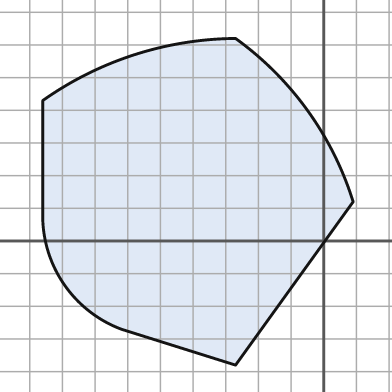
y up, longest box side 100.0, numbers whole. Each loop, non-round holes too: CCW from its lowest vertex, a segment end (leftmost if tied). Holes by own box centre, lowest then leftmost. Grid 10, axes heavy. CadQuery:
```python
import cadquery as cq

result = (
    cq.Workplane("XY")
    .moveTo(-27.0, -38.0)
    .lineTo(9.0, 12.0)
    .threePointArc((-5.0, 40.0), (-27.0, 62.0))
    .threePointArc((-58.0, 57.0), (-86.0, 43.0))
    .lineTo(-86.0, 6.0)
    .threePointArc((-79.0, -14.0), (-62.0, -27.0))
    .close()
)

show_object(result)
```